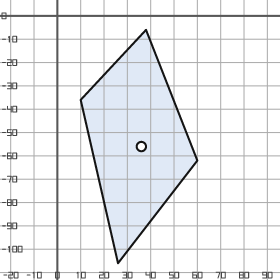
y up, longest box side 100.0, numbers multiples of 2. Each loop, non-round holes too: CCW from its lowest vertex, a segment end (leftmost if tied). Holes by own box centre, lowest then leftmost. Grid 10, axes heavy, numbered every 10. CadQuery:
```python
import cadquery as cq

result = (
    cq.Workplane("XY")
    .moveTo(26.0, -106.0)
    .lineTo(60.0, -62.0)
    .lineTo(38.0, -6.0)
    .lineTo(10.0, -36.0)
    .close()
    .moveTo(36.0, -56.0)
    .circle(2.0)
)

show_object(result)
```